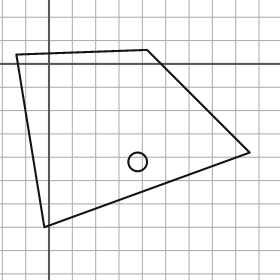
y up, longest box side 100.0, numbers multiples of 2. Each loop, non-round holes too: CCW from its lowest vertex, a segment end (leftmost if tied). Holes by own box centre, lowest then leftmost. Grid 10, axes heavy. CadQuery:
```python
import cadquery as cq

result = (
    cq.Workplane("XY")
    .moveTo(-2.0, -70.0)
    .lineTo(86.0, -38.0)
    .lineTo(42.0, 6.0)
    .lineTo(-14.0, 4.0)
    .close()
    .moveTo(38.0, -42.0)
    .circle(4.0)
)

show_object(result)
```